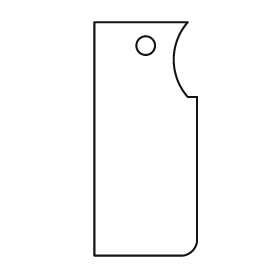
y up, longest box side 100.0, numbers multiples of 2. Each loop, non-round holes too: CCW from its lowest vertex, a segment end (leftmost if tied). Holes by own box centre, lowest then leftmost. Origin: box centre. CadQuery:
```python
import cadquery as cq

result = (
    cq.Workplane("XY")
    .moveTo(-22.0, -50.0)
    .lineTo(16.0, -50.0)
    .threePointArc((20.0, -48.0), (22.0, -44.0))
    .lineTo(22.0, 18.0)
    .lineTo(18.0, 18.0)
    .threePointArc((12.0, 34.0), (18.0, 50.0))
    .lineTo(-22.0, 50.0)
    .close()
    .moveTo(0.0, 40.0)
    .circle(4.0)
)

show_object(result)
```